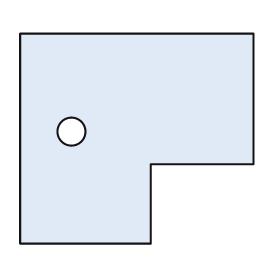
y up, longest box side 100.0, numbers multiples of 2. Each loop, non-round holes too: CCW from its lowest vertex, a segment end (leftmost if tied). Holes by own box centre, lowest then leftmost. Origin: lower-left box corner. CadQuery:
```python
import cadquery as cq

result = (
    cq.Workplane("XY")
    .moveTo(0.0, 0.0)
    .lineTo(56.0, 0.0)
    .lineTo(56.0, 34.0)
    .lineTo(100.0, 34.0)
    .lineTo(100.0, 90.0)
    .lineTo(0.0, 90.0)
    .close()
    .moveTo(22.0, 48.0)
    .circle(6.0)
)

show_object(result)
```